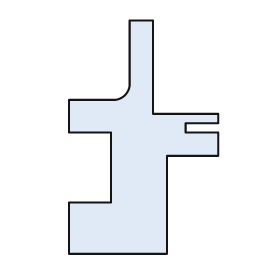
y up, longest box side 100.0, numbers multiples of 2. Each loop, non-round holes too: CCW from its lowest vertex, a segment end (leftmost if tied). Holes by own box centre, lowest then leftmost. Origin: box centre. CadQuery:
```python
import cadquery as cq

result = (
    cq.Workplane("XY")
    .moveTo(-32.0, -50.0)
    .lineTo(10.0, -50.0)
    .lineTo(10.0, -8.0)
    .lineTo(32.0, -8.0)
    .lineTo(32.0, 2.0)
    .lineTo(18.0, 2.0)
    .lineTo(18.0, 6.0)
    .lineTo(32.0, 6.0)
    .lineTo(32.0, 10.0)
    .lineTo(4.0, 10.0)
    .lineTo(4.0, 50.0)
    .lineTo(-6.0, 50.0)
    .lineTo(-6.0, 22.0)
    .threePointArc((-8.0, 18.0), (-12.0, 16.0))
    .lineTo(-32.0, 16.0)
    .lineTo(-32.0, 2.0)
    .lineTo(-14.0, 2.0)
    .lineTo(-14.0, -28.0)
    .lineTo(-32.0, -28.0)
    .close()
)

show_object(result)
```